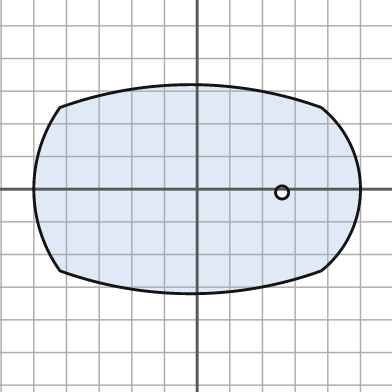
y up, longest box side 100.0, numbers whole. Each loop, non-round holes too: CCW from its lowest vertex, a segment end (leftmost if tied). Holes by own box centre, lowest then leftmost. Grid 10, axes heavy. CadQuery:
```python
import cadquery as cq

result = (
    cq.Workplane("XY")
    .moveTo(-42.0, -25.0)
    .threePointArc((-2.0, -32.0), (38.0, -25.0))
    .threePointArc((50.0, 0.0), (38.0, 25.0))
    .threePointArc((-2.0, 32.0), (-42.0, 25.0))
    .threePointArc((-50.0, 0.0), (-42.0, -25.0))
    .close()
    .moveTo(26.0, -1.0)
    .circle(2.0)
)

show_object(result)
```